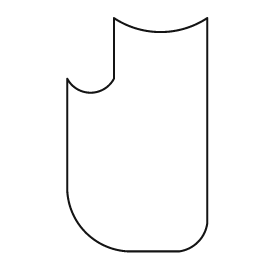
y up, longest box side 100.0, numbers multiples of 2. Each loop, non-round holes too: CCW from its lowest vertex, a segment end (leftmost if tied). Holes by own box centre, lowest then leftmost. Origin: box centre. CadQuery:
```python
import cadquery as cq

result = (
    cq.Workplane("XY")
    .moveTo(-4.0, -50.0)
    .lineTo(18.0, -50.0)
    .threePointArc((26.0, -46.0), (30.0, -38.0))
    .lineTo(30.0, 50.0)
    .threePointArc((10.0, 44.0), (-10.0, 50.0))
    .lineTo(-10.0, 24.0)
    .threePointArc((-20.0, 18.0), (-30.0, 24.0))
    .lineTo(-30.0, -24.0)
    .threePointArc((-22.0, -42.0), (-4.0, -50.0))
    .close()
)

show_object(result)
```